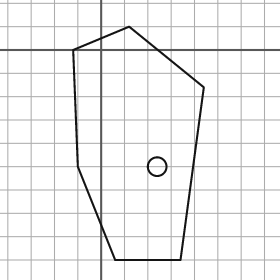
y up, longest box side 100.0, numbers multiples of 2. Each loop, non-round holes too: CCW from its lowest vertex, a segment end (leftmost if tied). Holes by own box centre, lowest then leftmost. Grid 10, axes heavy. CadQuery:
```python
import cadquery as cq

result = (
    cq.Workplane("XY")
    .moveTo(6.0, -90.0)
    .lineTo(34.0, -90.0)
    .lineTo(44.0, -16.0)
    .lineTo(12.0, 10.0)
    .lineTo(-12.0, 0.0)
    .lineTo(-10.0, -50.0)
    .close()
    .moveTo(24.0, -50.0)
    .circle(4.0)
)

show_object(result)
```